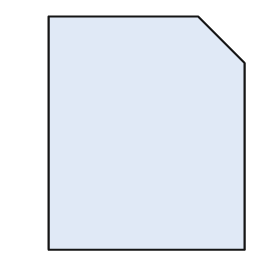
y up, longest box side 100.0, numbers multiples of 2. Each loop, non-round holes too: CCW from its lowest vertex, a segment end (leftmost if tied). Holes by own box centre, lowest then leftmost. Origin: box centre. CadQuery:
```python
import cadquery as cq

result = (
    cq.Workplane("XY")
    .moveTo(-42.0, -50.0)
    .lineTo(42.0, -50.0)
    .lineTo(42.0, 30.0)
    .lineTo(22.0, 50.0)
    .lineTo(-42.0, 50.0)
    .close()
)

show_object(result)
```